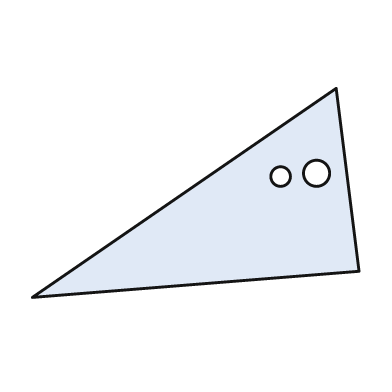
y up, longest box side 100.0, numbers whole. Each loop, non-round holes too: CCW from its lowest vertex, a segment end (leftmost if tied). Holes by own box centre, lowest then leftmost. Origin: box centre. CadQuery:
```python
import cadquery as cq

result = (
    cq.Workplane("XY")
    .moveTo(-50.0, -32.0)
    .lineTo(50.0, -24.0)
    .lineTo(43.0, 32.0)
    .close()
    .moveTo(26.0, 5.0)
    .circle(3.0)
    .moveTo(37.0, 6.0)
    .circle(4.0)
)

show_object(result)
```